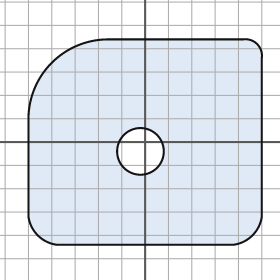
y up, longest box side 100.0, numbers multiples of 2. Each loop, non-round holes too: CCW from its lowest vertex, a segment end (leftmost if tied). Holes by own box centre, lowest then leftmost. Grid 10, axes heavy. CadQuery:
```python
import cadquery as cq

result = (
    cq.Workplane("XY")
    .moveTo(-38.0, -44.0)
    .lineTo(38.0, -44.0)
    .threePointArc((46.0, -40.0), (50.0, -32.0))
    .lineTo(50.0, 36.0)
    .threePointArc((48.0, 42.0), (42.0, 44.0))
    .lineTo(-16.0, 44.0)
    .threePointArc((-40.0, 34.0), (-50.0, 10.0))
    .lineTo(-50.0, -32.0)
    .threePointArc((-46.0, -40.0), (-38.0, -44.0))
    .close()
    .moveTo(-2.0, -4.0)
    .circle(10.0)
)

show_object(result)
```